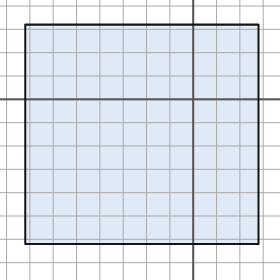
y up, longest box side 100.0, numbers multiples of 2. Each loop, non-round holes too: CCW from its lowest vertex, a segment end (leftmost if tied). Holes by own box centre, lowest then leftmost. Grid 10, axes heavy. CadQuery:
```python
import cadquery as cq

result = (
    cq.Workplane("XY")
    .moveTo(-72.0, -62.0)
    .lineTo(28.0, -62.0)
    .lineTo(28.0, 32.0)
    .lineTo(-72.0, 32.0)
    .close()
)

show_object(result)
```